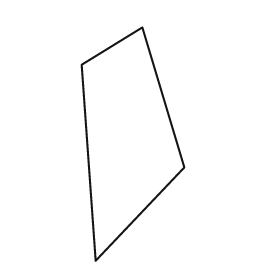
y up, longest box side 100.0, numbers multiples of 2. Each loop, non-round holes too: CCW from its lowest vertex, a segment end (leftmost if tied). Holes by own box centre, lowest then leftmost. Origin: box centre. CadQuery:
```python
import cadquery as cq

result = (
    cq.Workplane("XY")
    .moveTo(-16.0, -50.0)
    .lineTo(22.0, -10.0)
    .lineTo(4.0, 50.0)
    .lineTo(-22.0, 34.0)
    .close()
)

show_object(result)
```